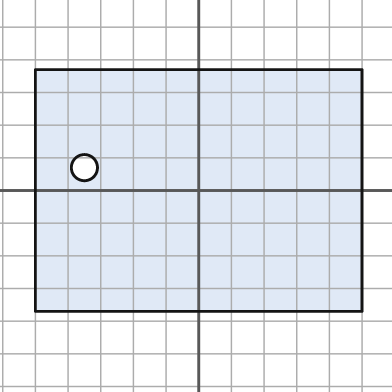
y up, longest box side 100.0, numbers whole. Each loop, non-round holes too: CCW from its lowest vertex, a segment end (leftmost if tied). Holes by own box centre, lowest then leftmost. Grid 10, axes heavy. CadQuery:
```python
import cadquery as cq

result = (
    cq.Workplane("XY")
    .moveTo(-50.0, -37.0)
    .lineTo(50.0, -37.0)
    .lineTo(50.0, 37.0)
    .lineTo(-50.0, 37.0)
    .close()
    .moveTo(-35.0, 7.0)
    .circle(4.0)
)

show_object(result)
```